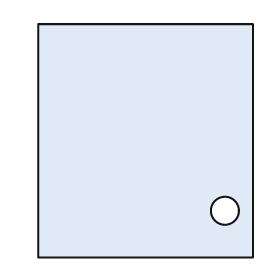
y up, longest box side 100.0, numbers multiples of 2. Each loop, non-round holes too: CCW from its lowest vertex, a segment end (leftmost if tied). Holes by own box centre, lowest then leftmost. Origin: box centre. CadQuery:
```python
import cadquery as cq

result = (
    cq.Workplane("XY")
    .moveTo(-46.0, -50.0)
    .lineTo(46.0, -50.0)
    .lineTo(46.0, 50.0)
    .lineTo(-46.0, 50.0)
    .close()
    .moveTo(34.0, -30.0)
    .circle(6.0)
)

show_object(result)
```